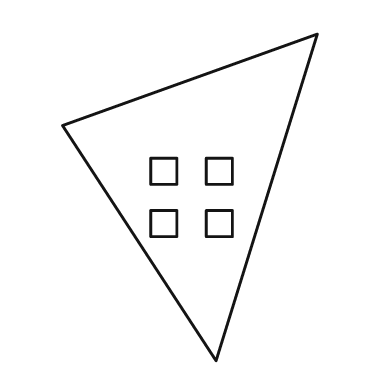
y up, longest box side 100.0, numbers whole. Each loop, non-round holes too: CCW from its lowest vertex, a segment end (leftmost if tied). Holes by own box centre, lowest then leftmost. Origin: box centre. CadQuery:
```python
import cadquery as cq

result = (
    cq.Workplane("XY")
    .moveTo(8.0, -50.0)
    .lineTo(39.0, 50.0)
    .lineTo(-39.0, 22.0)
    .close()
    .moveTo(-12.0, -12.0)
    .lineTo(-4.0, -12.0)
    .lineTo(-4.0, -4.0)
    .lineTo(-12.0, -4.0)
    .close()
    .moveTo(5.0, -12.0)
    .lineTo(13.0, -12.0)
    .lineTo(13.0, -4.0)
    .lineTo(5.0, -4.0)
    .close()
    .moveTo(-12.0, 4.0)
    .lineTo(-4.0, 4.0)
    .lineTo(-4.0, 12.0)
    .lineTo(-12.0, 12.0)
    .close()
    .moveTo(5.0, 4.0)
    .lineTo(13.0, 4.0)
    .lineTo(13.0, 12.0)
    .lineTo(5.0, 12.0)
    .close()
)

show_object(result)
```